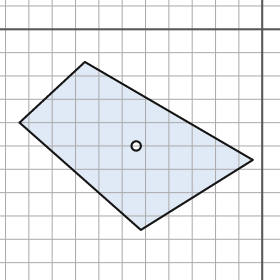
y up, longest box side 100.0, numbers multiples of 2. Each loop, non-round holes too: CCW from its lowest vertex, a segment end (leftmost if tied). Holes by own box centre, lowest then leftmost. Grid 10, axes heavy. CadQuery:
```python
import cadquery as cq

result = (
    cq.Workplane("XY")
    .moveTo(-52.0, -86.0)
    .lineTo(-4.0, -56.0)
    .lineTo(-76.0, -14.0)
    .lineTo(-104.0, -40.0)
    .close()
    .moveTo(-54.0, -50.0)
    .circle(2.0)
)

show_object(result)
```